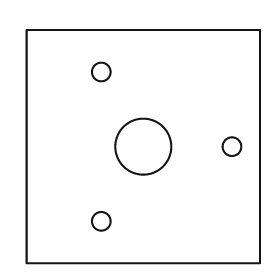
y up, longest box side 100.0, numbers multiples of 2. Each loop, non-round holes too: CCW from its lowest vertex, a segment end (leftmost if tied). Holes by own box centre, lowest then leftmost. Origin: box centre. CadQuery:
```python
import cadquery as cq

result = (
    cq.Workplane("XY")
    .moveTo(-50.0, -50.0)
    .lineTo(50.0, -50.0)
    .lineTo(50.0, 50.0)
    .lineTo(-50.0, 50.0)
    .close()
    .moveTo(-18.0, -32.0)
    .circle(4.0)
    .moveTo(0.0, 0.0)
    .circle(12.0)
    .moveTo(38.0, 0.0)
    .circle(4.0)
    .moveTo(-18.0, 32.0)
    .circle(4.0)
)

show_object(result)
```